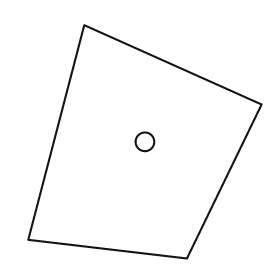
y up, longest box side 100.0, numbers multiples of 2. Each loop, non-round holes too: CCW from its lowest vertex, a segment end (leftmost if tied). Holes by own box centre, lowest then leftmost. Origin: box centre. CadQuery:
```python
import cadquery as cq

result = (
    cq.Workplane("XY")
    .moveTo(18.0, -50.0)
    .lineTo(50.0, 16.0)
    .lineTo(-26.0, 50.0)
    .lineTo(-50.0, -42.0)
    .close()
    .moveTo(0.0, 0.0)
    .circle(4.0)
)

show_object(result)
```